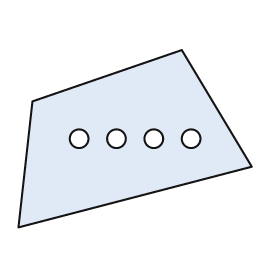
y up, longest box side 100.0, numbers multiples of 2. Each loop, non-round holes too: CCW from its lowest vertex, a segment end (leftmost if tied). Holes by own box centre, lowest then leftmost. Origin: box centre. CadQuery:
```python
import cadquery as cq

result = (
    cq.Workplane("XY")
    .moveTo(-50.0, -38.0)
    .lineTo(50.0, -12.0)
    .lineTo(20.0, 38.0)
    .lineTo(-44.0, 16.0)
    .close()
    .moveTo(-24.0, 0.0)
    .circle(4.0)
    .moveTo(-8.0, 0.0)
    .circle(4.0)
    .moveTo(8.0, 0.0)
    .circle(4.0)
    .moveTo(24.0, 0.0)
    .circle(4.0)
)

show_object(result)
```